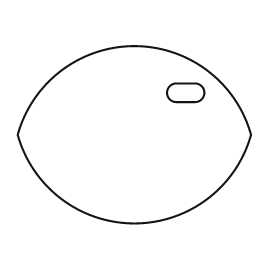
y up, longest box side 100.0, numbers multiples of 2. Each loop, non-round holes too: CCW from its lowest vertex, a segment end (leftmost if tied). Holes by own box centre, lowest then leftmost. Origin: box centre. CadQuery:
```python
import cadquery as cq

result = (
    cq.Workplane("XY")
    .moveTo(-50.0, 0.0)
    .threePointArc((0.0, -38.0), (50.0, 0.0))
    .threePointArc((0.0, 38.0), (-50.0, 0.0))
    .close()
    .moveTo(18.0, 14.0)
    .lineTo(26.0, 14.0)
    .threePointArc((30.0, 18.0), (26.0, 22.0))
    .lineTo(18.0, 22.0)
    .threePointArc((14.0, 18.0), (18.0, 14.0))
    .close()
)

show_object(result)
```